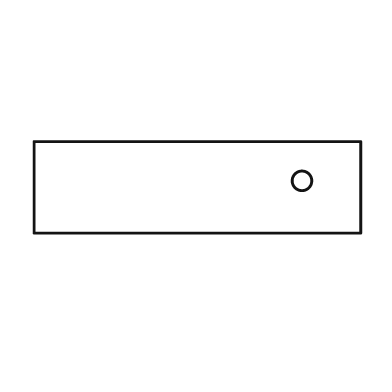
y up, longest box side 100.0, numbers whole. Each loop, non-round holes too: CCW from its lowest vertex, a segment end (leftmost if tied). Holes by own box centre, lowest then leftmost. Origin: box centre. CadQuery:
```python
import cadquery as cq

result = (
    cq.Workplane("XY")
    .moveTo(-50.0, -14.0)
    .lineTo(50.0, -14.0)
    .lineTo(50.0, 14.0)
    .lineTo(-50.0, 14.0)
    .close()
    .moveTo(32.0, 2.0)
    .circle(3.0)
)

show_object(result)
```